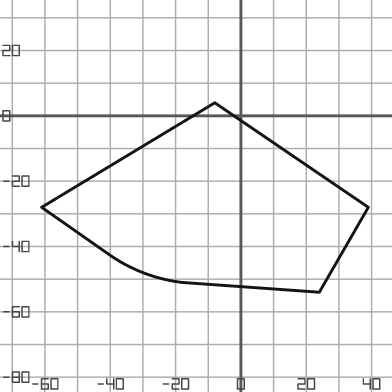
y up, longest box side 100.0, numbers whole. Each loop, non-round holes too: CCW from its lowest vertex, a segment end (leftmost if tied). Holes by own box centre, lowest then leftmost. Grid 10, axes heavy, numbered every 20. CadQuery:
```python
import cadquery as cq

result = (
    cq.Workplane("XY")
    .moveTo(24.0, -54.0)
    .lineTo(39.0, -28.0)
    .lineTo(-8.0, 4.0)
    .lineTo(-61.0, -28.0)
    .lineTo(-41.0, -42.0)
    .threePointArc((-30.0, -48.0), (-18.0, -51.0))
    .close()
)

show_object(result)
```